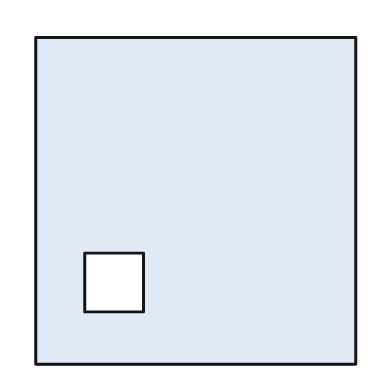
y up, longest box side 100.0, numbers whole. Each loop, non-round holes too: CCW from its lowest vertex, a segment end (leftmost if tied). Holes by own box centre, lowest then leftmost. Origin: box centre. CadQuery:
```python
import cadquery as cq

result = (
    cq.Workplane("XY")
    .moveTo(-49.0, -50.0)
    .lineTo(49.0, -50.0)
    .lineTo(49.0, 50.0)
    .lineTo(-49.0, 50.0)
    .close()
    .moveTo(-34.0, -34.0)
    .lineTo(-16.0, -34.0)
    .lineTo(-16.0, -16.0)
    .lineTo(-34.0, -16.0)
    .close()
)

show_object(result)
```